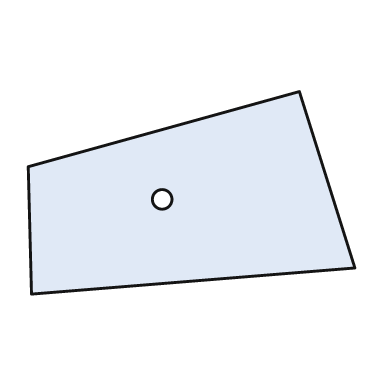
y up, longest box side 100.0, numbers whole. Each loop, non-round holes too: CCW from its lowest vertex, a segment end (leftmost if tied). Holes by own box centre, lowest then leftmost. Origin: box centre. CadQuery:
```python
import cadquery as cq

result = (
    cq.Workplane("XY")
    .moveTo(-49.0, -31.0)
    .lineTo(50.0, -23.0)
    .lineTo(33.0, 31.0)
    .lineTo(-50.0, 8.0)
    .close()
    .moveTo(-9.0, -2.0)
    .circle(3.0)
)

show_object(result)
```